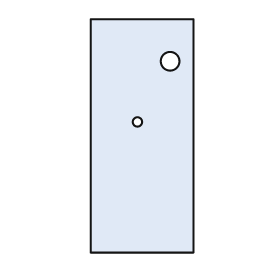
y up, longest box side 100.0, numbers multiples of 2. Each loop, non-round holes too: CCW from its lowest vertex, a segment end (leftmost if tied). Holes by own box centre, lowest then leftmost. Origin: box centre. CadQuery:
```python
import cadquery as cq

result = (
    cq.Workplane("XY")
    .moveTo(-22.0, -50.0)
    .lineTo(22.0, -50.0)
    .lineTo(22.0, 50.0)
    .lineTo(-22.0, 50.0)
    .close()
    .moveTo(-2.0, 6.0)
    .circle(2.0)
    .moveTo(12.0, 32.0)
    .circle(4.0)
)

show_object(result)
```